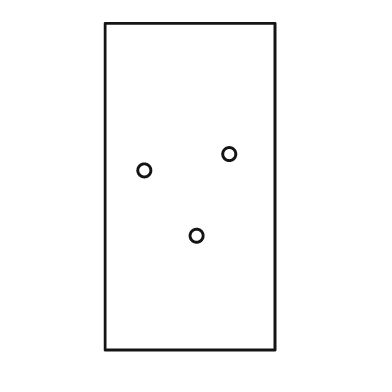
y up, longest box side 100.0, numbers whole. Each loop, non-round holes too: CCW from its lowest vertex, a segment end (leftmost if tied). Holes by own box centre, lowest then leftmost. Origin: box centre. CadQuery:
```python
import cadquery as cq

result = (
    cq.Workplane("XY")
    .moveTo(-26.0, -50.0)
    .lineTo(26.0, -50.0)
    .lineTo(26.0, 50.0)
    .lineTo(-26.0, 50.0)
    .close()
    .moveTo(2.0, -15.0)
    .circle(2.0)
    .moveTo(-14.0, 5.0)
    .circle(2.0)
    .moveTo(12.0, 10.0)
    .circle(2.0)
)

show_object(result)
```